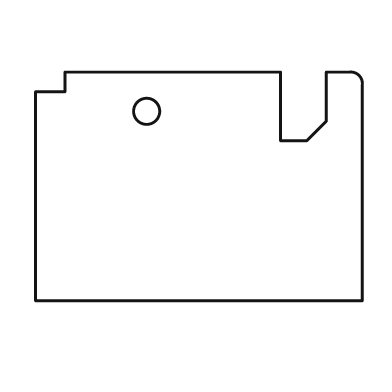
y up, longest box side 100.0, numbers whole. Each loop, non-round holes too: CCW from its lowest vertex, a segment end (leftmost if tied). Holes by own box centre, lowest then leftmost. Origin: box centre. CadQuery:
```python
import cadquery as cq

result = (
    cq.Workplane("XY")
    .moveTo(-50.0, -35.0)
    .lineTo(50.0, -35.0)
    .lineTo(50.0, 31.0)
    .threePointArc((49.0, 34.0), (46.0, 35.0))
    .lineTo(39.0, 35.0)
    .lineTo(39.0, 20.0)
    .lineTo(33.0, 14.0)
    .lineTo(25.0, 14.0)
    .lineTo(25.0, 35.0)
    .lineTo(-41.0, 35.0)
    .lineTo(-41.0, 29.0)
    .lineTo(-50.0, 29.0)
    .close()
    .moveTo(-16.0, 23.0)
    .circle(4.0)
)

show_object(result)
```